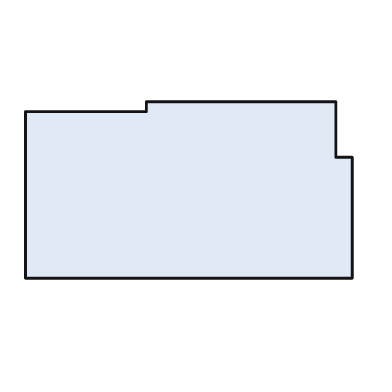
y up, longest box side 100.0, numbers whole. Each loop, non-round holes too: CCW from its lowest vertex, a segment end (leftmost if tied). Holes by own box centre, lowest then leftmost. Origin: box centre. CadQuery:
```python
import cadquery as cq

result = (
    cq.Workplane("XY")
    .moveTo(-50.0, -27.0)
    .lineTo(50.0, -27.0)
    .lineTo(50.0, 10.0)
    .lineTo(45.0, 10.0)
    .lineTo(45.0, 27.0)
    .lineTo(-13.0, 27.0)
    .lineTo(-13.0, 24.0)
    .lineTo(-50.0, 24.0)
    .close()
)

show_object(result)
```